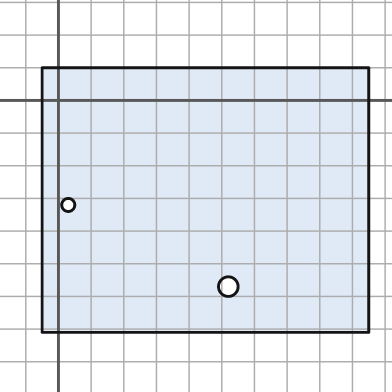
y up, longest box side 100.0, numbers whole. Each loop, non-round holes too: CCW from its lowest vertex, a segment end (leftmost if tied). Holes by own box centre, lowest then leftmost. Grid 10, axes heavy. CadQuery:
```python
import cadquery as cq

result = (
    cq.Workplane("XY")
    .moveTo(-5.0, -71.0)
    .lineTo(95.0, -71.0)
    .lineTo(95.0, 10.0)
    .lineTo(-5.0, 10.0)
    .close()
    .moveTo(52.0, -57.0)
    .circle(3.0)
    .moveTo(3.0, -32.0)
    .circle(2.0)
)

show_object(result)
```